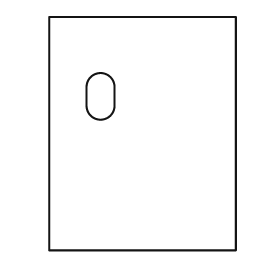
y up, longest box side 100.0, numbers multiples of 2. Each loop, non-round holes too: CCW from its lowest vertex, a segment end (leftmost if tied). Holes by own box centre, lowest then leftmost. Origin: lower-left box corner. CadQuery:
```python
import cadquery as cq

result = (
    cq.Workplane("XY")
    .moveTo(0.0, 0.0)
    .lineTo(80.0, 0.0)
    .lineTo(80.0, 100.0)
    .lineTo(0.0, 100.0)
    .close()
    .moveTo(16.0, 62.0)
    .threePointArc((22.0, 56.0), (28.0, 62.0))
    .lineTo(28.0, 70.0)
    .threePointArc((22.0, 76.0), (16.0, 70.0))
    .close()
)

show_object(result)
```